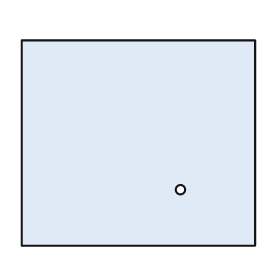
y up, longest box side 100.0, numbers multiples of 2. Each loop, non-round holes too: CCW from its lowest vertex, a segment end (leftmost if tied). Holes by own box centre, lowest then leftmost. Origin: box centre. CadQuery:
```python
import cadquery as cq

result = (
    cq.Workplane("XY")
    .moveTo(-50.0, -44.0)
    .lineTo(50.0, -44.0)
    .lineTo(50.0, 44.0)
    .lineTo(-50.0, 44.0)
    .close()
    .moveTo(18.0, -20.0)
    .circle(2.0)
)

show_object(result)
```